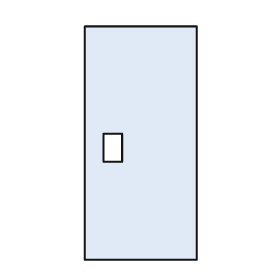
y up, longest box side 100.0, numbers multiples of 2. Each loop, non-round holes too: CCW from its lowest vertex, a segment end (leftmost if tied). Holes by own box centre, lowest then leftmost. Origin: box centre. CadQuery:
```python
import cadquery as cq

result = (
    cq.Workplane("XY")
    .moveTo(-24.0, -50.0)
    .lineTo(24.0, -50.0)
    .lineTo(24.0, 50.0)
    .lineTo(-24.0, 50.0)
    .close()
    .moveTo(-16.0, -8.0)
    .lineTo(-8.0, -8.0)
    .lineTo(-8.0, 4.0)
    .lineTo(-16.0, 4.0)
    .close()
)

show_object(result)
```